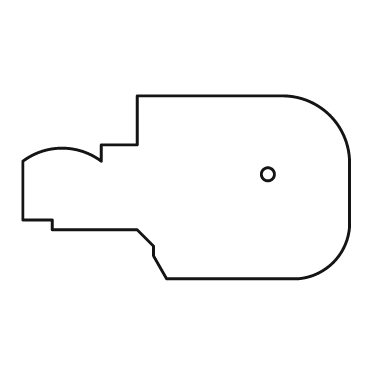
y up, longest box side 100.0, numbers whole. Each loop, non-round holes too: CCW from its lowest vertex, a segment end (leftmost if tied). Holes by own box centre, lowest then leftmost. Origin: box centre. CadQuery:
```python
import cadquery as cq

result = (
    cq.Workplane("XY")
    .moveTo(-6.0, -28.0)
    .lineTo(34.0, -28.0)
    .threePointArc((45.0, -23.0), (50.0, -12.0))
    .lineTo(50.0, 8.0)
    .threePointArc((44.0, 22.0), (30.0, 28.0))
    .lineTo(-15.0, 28.0)
    .lineTo(-15.0, 13.0)
    .lineTo(-26.0, 13.0)
    .lineTo(-26.0, 8.0)
    .threePointArc((-38.0, 12.0), (-50.0, 8.0))
    .lineTo(-50.0, -10.0)
    .lineTo(-41.0, -10.0)
    .lineTo(-41.0, -13.0)
    .lineTo(-15.0, -13.0)
    .lineTo(-10.0, -18.0)
    .lineTo(-10.0, -21.0)
    .close()
    .moveTo(25.0, 4.0)
    .circle(2.0)
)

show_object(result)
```